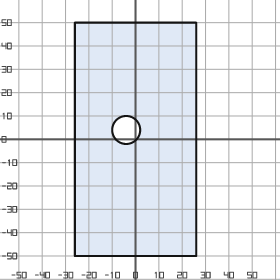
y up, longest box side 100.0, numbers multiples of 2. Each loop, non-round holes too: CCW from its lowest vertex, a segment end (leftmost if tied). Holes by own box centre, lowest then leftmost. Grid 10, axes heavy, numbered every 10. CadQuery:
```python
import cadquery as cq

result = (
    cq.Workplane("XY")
    .moveTo(-26.0, -50.0)
    .lineTo(26.0, -50.0)
    .lineTo(26.0, 50.0)
    .lineTo(-26.0, 50.0)
    .close()
    .moveTo(-4.0, 4.0)
    .circle(6.0)
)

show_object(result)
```